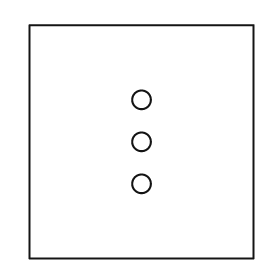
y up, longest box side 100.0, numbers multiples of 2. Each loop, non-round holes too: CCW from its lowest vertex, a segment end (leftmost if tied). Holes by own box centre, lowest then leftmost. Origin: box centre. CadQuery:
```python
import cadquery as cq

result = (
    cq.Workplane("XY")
    .moveTo(-48.0, -50.0)
    .lineTo(48.0, -50.0)
    .lineTo(48.0, 50.0)
    .lineTo(-48.0, 50.0)
    .close()
    .moveTo(0.0, -18.0)
    .circle(4.0)
    .moveTo(0.0, 0.0)
    .circle(4.0)
    .moveTo(0.0, 18.0)
    .circle(4.0)
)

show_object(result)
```